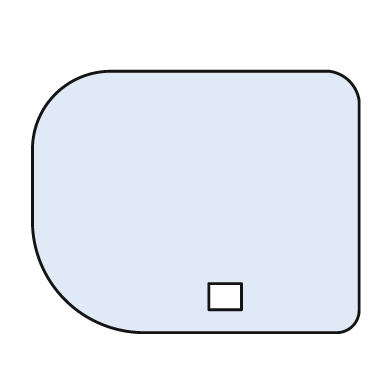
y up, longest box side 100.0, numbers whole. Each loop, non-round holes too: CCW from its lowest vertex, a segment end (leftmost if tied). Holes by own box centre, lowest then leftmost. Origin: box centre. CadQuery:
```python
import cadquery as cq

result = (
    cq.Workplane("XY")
    .moveTo(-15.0, -40.0)
    .lineTo(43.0, -40.0)
    .threePointArc((48.0, -38.0), (50.0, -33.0))
    .lineTo(50.0, 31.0)
    .threePointArc((47.0, 37.0), (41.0, 40.0))
    .lineTo(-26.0, 40.0)
    .threePointArc((-43.0, 33.0), (-50.0, 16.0))
    .lineTo(-50.0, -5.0)
    .threePointArc((-40.0, -30.0), (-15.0, -40.0))
    .close()
    .moveTo(4.0, -33.0)
    .lineTo(14.0, -33.0)
    .lineTo(14.0, -25.0)
    .lineTo(4.0, -25.0)
    .close()
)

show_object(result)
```